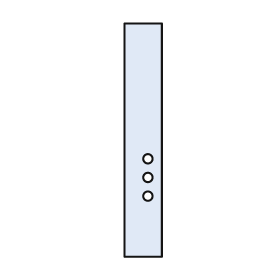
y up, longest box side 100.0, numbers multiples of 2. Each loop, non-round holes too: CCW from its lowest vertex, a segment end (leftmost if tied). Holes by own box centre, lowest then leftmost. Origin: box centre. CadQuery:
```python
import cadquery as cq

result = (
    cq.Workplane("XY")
    .moveTo(-8.0, -50.0)
    .lineTo(8.0, -50.0)
    .lineTo(8.0, 50.0)
    .lineTo(-8.0, 50.0)
    .close()
    .moveTo(2.0, -24.0)
    .circle(2.0)
    .moveTo(2.0, -16.0)
    .circle(2.0)
    .moveTo(2.0, -8.0)
    .circle(2.0)
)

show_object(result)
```